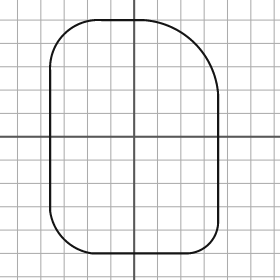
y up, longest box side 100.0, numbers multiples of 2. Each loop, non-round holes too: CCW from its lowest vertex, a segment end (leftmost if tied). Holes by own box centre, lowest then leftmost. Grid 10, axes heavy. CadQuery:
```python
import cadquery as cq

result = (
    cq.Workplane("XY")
    .moveTo(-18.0, -50.0)
    .lineTo(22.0, -50.0)
    .threePointArc((32.0, -46.0), (36.0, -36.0))
    .lineTo(36.0, 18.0)
    .threePointArc((26.0, 40.0), (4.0, 50.0))
    .lineTo(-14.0, 50.0)
    .threePointArc((-30.0, 44.0), (-36.0, 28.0))
    .lineTo(-36.0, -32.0)
    .threePointArc((-30.0, -44.0), (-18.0, -50.0))
    .close()
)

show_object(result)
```